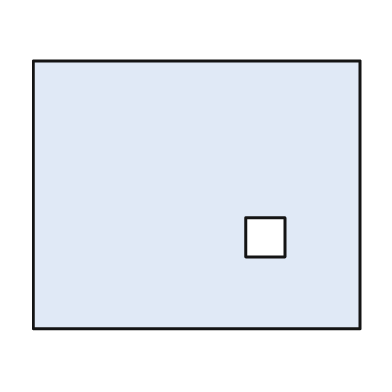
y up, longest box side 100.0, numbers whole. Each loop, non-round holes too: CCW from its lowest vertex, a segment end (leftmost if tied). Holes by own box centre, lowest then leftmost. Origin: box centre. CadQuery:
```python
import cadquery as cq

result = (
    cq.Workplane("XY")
    .moveTo(-50.0, -41.0)
    .lineTo(50.0, -41.0)
    .lineTo(50.0, 41.0)
    .lineTo(-50.0, 41.0)
    .close()
    .moveTo(15.0, -19.0)
    .lineTo(27.0, -19.0)
    .lineTo(27.0, -7.0)
    .lineTo(15.0, -7.0)
    .close()
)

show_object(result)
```